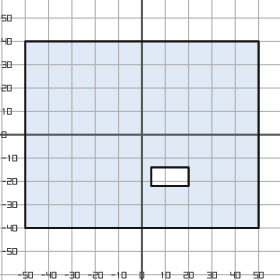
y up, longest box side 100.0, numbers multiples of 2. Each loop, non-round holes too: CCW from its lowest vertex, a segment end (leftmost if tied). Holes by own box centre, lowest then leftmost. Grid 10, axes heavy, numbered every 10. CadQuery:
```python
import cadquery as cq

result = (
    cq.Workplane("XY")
    .moveTo(-50.0, -40.0)
    .lineTo(50.0, -40.0)
    .lineTo(50.0, 40.0)
    .lineTo(-50.0, 40.0)
    .close()
    .moveTo(4.0, -22.0)
    .lineTo(20.0, -22.0)
    .lineTo(20.0, -14.0)
    .lineTo(4.0, -14.0)
    .close()
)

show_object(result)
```